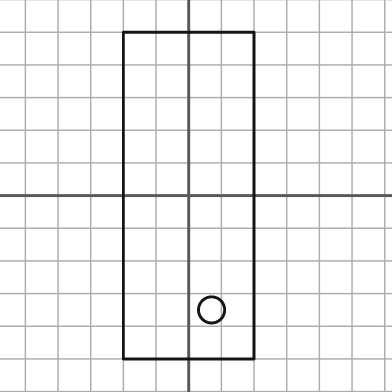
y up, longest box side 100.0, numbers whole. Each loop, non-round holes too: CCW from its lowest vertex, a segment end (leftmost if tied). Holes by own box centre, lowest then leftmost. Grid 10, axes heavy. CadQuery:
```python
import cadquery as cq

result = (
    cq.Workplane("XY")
    .moveTo(-20.0, -50.0)
    .lineTo(20.0, -50.0)
    .lineTo(20.0, 50.0)
    .lineTo(-20.0, 50.0)
    .close()
    .moveTo(7.0, -35.0)
    .circle(4.0)
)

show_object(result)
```